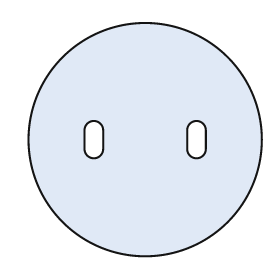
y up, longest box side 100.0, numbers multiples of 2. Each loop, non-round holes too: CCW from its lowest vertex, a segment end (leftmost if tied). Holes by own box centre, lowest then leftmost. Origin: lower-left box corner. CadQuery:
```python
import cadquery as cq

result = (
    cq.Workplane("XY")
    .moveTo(50.0, 50.0)
    .circle(50.0)
    .moveTo(24.0, 46.0)
    .threePointArc((28.0, 42.0), (32.0, 46.0))
    .lineTo(32.0, 54.0)
    .threePointArc((28.0, 58.0), (24.0, 54.0))
    .close()
    .moveTo(68.0, 46.0)
    .threePointArc((72.0, 42.0), (76.0, 46.0))
    .lineTo(76.0, 54.0)
    .threePointArc((72.0, 58.0), (68.0, 54.0))
    .close()
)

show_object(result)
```